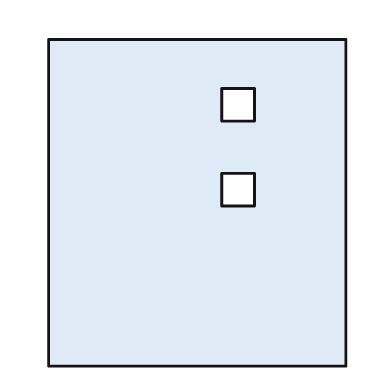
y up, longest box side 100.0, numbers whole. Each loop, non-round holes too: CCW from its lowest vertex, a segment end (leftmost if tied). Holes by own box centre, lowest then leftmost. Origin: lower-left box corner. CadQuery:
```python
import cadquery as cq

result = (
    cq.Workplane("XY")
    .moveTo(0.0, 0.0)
    .lineTo(91.0, 0.0)
    .lineTo(91.0, 100.0)
    .lineTo(0.0, 100.0)
    .close()
    .moveTo(53.0, 49.0)
    .lineTo(63.0, 49.0)
    .lineTo(63.0, 59.0)
    .lineTo(53.0, 59.0)
    .close()
    .moveTo(53.0, 75.0)
    .lineTo(63.0, 75.0)
    .lineTo(63.0, 85.0)
    .lineTo(53.0, 85.0)
    .close()
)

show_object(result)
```